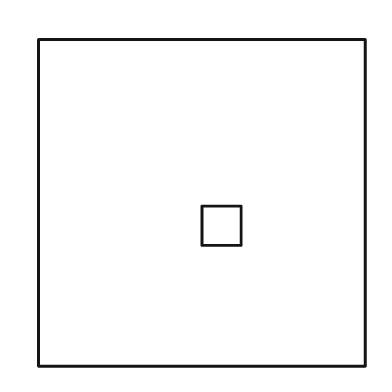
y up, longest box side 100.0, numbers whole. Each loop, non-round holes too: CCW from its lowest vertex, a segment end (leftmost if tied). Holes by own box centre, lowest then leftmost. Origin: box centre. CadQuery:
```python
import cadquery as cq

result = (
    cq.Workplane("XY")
    .moveTo(-50.0, -50.0)
    .lineTo(50.0, -50.0)
    .lineTo(50.0, 50.0)
    .lineTo(-50.0, 50.0)
    .close()
    .moveTo(0.0, -13.0)
    .lineTo(12.0, -13.0)
    .lineTo(12.0, -1.0)
    .lineTo(0.0, -1.0)
    .close()
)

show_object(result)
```